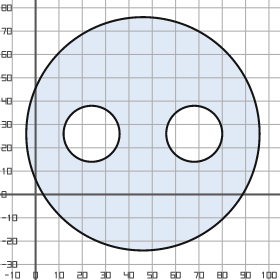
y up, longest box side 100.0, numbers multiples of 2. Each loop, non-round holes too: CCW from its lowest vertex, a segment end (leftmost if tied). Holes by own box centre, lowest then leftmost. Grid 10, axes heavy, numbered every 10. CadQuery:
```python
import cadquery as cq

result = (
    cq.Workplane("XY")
    .moveTo(46.0, 26.0)
    .circle(50.0)
    .moveTo(24.0, 26.0)
    .circle(12.0)
    .moveTo(68.0, 26.0)
    .circle(12.0)
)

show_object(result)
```